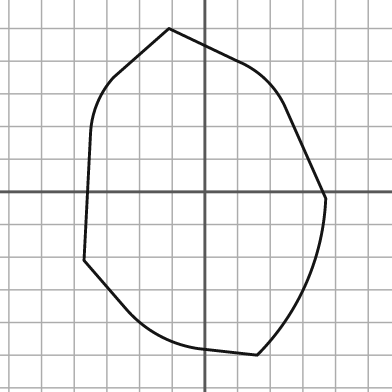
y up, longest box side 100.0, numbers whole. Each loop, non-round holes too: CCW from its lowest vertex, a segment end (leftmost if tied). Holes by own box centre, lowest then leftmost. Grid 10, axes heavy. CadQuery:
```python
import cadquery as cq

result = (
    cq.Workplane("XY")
    .moveTo(16.0, -50.0)
    .threePointArc((31.0, -28.0), (37.0, -2.0))
    .lineTo(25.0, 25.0)
    .threePointArc((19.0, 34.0), (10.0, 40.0))
    .lineTo(-11.0, 50.0)
    .lineTo(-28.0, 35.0)
    .threePointArc((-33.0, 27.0), (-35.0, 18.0))
    .lineTo(-37.0, -21.0)
    .lineTo(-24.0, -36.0)
    .threePointArc((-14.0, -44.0), (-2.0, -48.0))
    .close()
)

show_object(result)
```